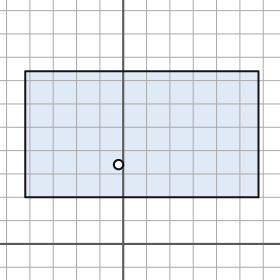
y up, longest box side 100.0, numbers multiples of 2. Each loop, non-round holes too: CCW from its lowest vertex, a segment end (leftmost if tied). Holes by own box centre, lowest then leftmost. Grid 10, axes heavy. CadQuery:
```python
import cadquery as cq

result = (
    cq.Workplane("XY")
    .moveTo(-42.0, 20.0)
    .lineTo(58.0, 20.0)
    .lineTo(58.0, 74.0)
    .lineTo(-42.0, 74.0)
    .close()
    .moveTo(-2.0, 34.0)
    .circle(2.0)
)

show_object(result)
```